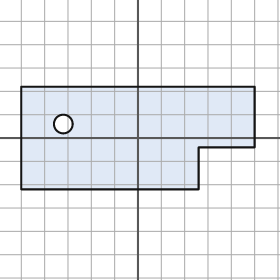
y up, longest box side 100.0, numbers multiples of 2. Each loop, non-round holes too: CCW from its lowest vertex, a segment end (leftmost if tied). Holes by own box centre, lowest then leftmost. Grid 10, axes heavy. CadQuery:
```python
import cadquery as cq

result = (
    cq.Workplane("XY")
    .moveTo(-50.0, -22.0)
    .lineTo(26.0, -22.0)
    .lineTo(26.0, -4.0)
    .lineTo(50.0, -4.0)
    .lineTo(50.0, 22.0)
    .lineTo(-50.0, 22.0)
    .close()
    .moveTo(-32.0, 6.0)
    .circle(4.0)
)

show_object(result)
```